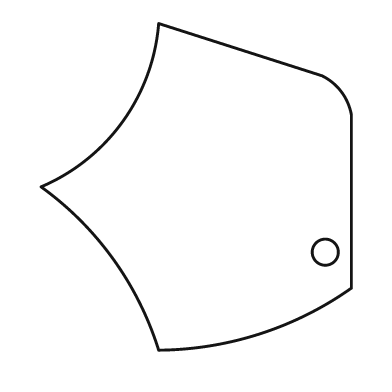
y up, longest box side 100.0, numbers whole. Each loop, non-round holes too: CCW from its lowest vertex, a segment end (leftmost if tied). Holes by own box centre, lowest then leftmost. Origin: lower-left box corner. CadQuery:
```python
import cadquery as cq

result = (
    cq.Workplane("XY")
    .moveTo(36.0, 0.0)
    .threePointArc((67.0, 5.0), (95.0, 19.0))
    .lineTo(95.0, 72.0)
    .threePointArc((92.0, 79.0), (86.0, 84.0))
    .lineTo(36.0, 100.0)
    .threePointArc((25.0, 70.0), (0.0, 50.0))
    .threePointArc((22.0, 28.0), (36.0, 0.0))
    .close()
    .moveTo(87.0, 30.0)
    .circle(4.0)
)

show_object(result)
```